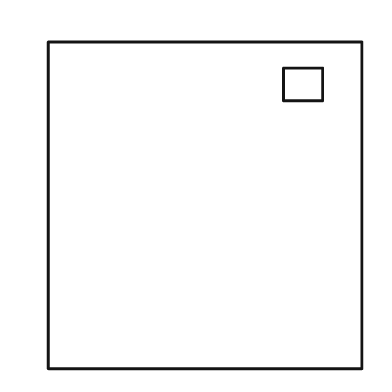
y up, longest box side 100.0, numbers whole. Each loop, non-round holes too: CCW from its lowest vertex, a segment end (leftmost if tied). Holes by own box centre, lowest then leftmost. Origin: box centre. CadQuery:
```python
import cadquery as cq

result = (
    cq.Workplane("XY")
    .moveTo(-48.0, -50.0)
    .lineTo(48.0, -50.0)
    .lineTo(48.0, 50.0)
    .lineTo(-48.0, 50.0)
    .close()
    .moveTo(24.0, 32.0)
    .lineTo(36.0, 32.0)
    .lineTo(36.0, 42.0)
    .lineTo(24.0, 42.0)
    .close()
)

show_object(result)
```